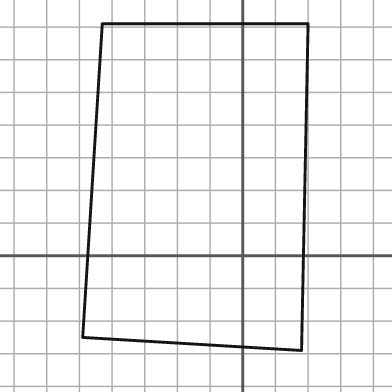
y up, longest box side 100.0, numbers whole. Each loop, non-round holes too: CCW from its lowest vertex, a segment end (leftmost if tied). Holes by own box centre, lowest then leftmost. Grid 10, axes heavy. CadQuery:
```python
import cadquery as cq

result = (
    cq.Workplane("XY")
    .moveTo(18.0, -29.0)
    .lineTo(20.0, 71.0)
    .lineTo(-43.0, 71.0)
    .lineTo(-49.0, -25.0)
    .close()
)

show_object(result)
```